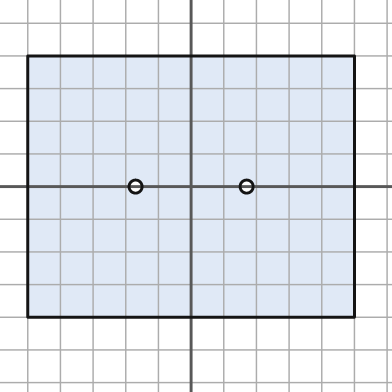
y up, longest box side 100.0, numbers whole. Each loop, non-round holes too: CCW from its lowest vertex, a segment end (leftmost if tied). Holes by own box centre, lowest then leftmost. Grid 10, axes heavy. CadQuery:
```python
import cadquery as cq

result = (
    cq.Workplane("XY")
    .moveTo(-50.0, -40.0)
    .lineTo(50.0, -40.0)
    .lineTo(50.0, 40.0)
    .lineTo(-50.0, 40.0)
    .close()
    .moveTo(-17.0, 0.0)
    .circle(2.0)
    .moveTo(17.0, 0.0)
    .circle(2.0)
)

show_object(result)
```